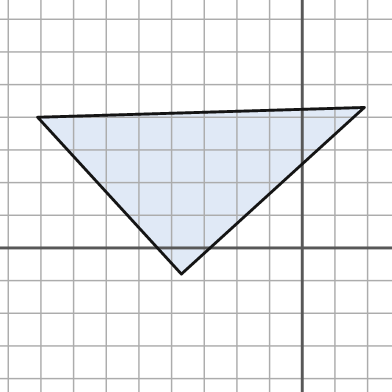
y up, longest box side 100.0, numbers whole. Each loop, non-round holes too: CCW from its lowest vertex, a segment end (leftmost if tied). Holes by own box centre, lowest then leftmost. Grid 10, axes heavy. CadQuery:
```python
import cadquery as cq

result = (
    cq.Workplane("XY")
    .moveTo(-37.0, -8.0)
    .lineTo(19.0, 43.0)
    .lineTo(-81.0, 40.0)
    .close()
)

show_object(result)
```